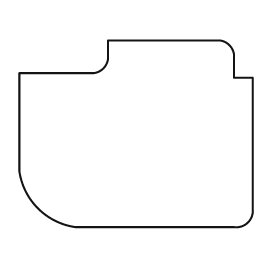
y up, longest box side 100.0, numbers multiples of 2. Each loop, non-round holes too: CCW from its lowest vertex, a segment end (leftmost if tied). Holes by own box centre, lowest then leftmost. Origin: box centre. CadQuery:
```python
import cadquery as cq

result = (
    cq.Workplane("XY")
    .moveTo(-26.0, -40.0)
    .lineTo(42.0, -40.0)
    .threePointArc((48.0, -38.0), (50.0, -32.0))
    .lineTo(50.0, 24.0)
    .lineTo(42.0, 24.0)
    .lineTo(42.0, 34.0)
    .threePointArc((40.0, 38.0), (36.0, 40.0))
    .lineTo(-12.0, 40.0)
    .lineTo(-12.0, 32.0)
    .threePointArc((-14.0, 28.0), (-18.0, 26.0))
    .lineTo(-50.0, 26.0)
    .lineTo(-50.0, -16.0)
    .threePointArc((-42.0, -32.0), (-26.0, -40.0))
    .close()
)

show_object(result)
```